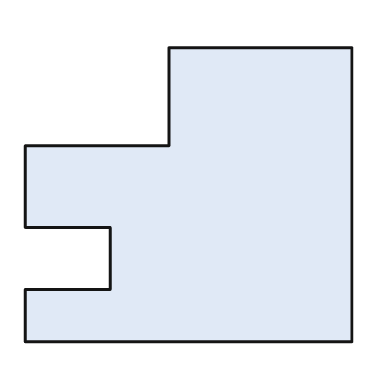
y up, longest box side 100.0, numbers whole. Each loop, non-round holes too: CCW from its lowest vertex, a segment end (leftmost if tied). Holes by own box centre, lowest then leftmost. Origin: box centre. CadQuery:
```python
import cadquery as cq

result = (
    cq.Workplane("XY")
    .moveTo(-50.0, -45.0)
    .lineTo(50.0, -45.0)
    .lineTo(50.0, 45.0)
    .lineTo(-6.0, 45.0)
    .lineTo(-6.0, 15.0)
    .lineTo(-50.0, 15.0)
    .lineTo(-50.0, -10.0)
    .lineTo(-24.0, -10.0)
    .lineTo(-24.0, -29.0)
    .lineTo(-50.0, -29.0)
    .close()
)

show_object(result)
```